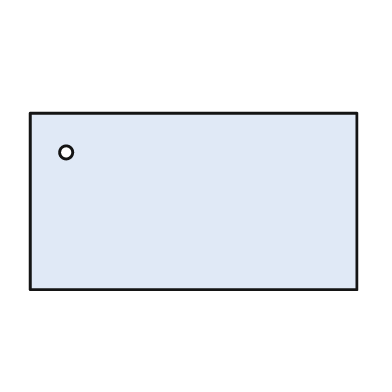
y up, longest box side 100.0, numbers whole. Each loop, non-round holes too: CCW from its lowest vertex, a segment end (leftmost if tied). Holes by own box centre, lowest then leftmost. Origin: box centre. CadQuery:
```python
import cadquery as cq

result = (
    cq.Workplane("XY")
    .moveTo(-50.0, -27.0)
    .lineTo(50.0, -27.0)
    .lineTo(50.0, 27.0)
    .lineTo(-50.0, 27.0)
    .close()
    .moveTo(-39.0, 15.0)
    .circle(2.0)
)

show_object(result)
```